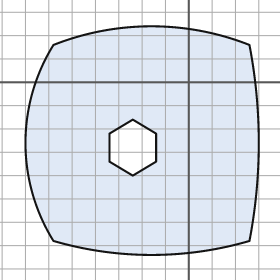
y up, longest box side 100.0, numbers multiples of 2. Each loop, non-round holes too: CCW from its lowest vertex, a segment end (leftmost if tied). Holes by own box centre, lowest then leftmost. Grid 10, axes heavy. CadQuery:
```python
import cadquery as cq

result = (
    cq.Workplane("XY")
    .moveTo(-58.0, -68.0)
    .threePointArc((-16.0, -74.0), (26.0, -68.0))
    .threePointArc((30.0, -26.0), (26.0, 16.0))
    .threePointArc((-16.0, 24.0), (-58.0, 16.0))
    .threePointArc((-70.0, -26.0), (-58.0, -68.0))
    .close()
    .moveTo(-24.0, -40.0)
    .lineTo(-14.0, -34.0)
    .lineTo(-14.0, -22.0)
    .lineTo(-24.0, -16.0)
    .lineTo(-34.0, -22.0)
    .lineTo(-34.0, -34.0)
    .close()
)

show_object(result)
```